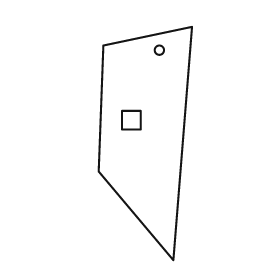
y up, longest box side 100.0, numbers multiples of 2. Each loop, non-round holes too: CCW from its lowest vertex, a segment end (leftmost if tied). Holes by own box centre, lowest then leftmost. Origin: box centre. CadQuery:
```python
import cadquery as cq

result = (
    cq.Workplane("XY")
    .moveTo(12.0, -50.0)
    .lineTo(20.0, 50.0)
    .lineTo(-18.0, 42.0)
    .lineTo(-20.0, -12.0)
    .close()
    .moveTo(-10.0, 6.0)
    .lineTo(-2.0, 6.0)
    .lineTo(-2.0, 14.0)
    .lineTo(-10.0, 14.0)
    .close()
    .moveTo(6.0, 40.0)
    .circle(2.0)
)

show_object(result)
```